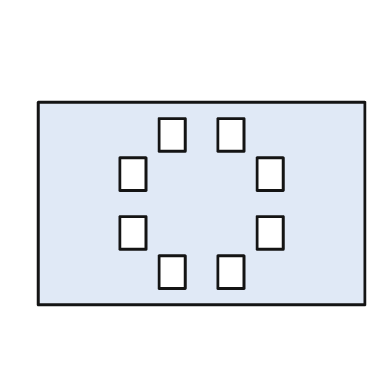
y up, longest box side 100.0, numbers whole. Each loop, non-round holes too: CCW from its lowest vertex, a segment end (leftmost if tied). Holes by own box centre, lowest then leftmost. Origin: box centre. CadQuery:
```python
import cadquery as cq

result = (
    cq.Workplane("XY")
    .moveTo(-50.0, -31.0)
    .lineTo(50.0, -31.0)
    .lineTo(50.0, 31.0)
    .lineTo(-50.0, 31.0)
    .close()
    .moveTo(-13.0, -26.0)
    .lineTo(-5.0, -26.0)
    .lineTo(-5.0, -16.0)
    .lineTo(-13.0, -16.0)
    .close()
    .moveTo(5.0, -26.0)
    .lineTo(13.0, -26.0)
    .lineTo(13.0, -16.0)
    .lineTo(5.0, -16.0)
    .close()
    .moveTo(-25.0, -14.0)
    .lineTo(-17.0, -14.0)
    .lineTo(-17.0, -4.0)
    .lineTo(-25.0, -4.0)
    .close()
    .moveTo(17.0, -14.0)
    .lineTo(25.0, -14.0)
    .lineTo(25.0, -4.0)
    .lineTo(17.0, -4.0)
    .close()
    .moveTo(-25.0, 4.0)
    .lineTo(-17.0, 4.0)
    .lineTo(-17.0, 14.0)
    .lineTo(-25.0, 14.0)
    .close()
    .moveTo(17.0, 4.0)
    .lineTo(25.0, 4.0)
    .lineTo(25.0, 14.0)
    .lineTo(17.0, 14.0)
    .close()
    .moveTo(-13.0, 16.0)
    .lineTo(-5.0, 16.0)
    .lineTo(-5.0, 26.0)
    .lineTo(-13.0, 26.0)
    .close()
    .moveTo(5.0, 16.0)
    .lineTo(13.0, 16.0)
    .lineTo(13.0, 26.0)
    .lineTo(5.0, 26.0)
    .close()
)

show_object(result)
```